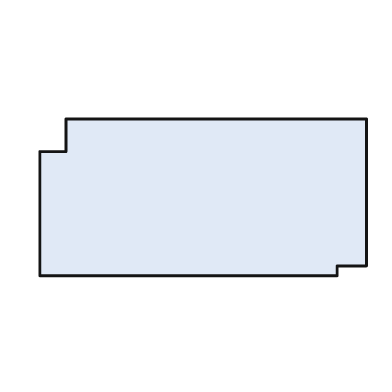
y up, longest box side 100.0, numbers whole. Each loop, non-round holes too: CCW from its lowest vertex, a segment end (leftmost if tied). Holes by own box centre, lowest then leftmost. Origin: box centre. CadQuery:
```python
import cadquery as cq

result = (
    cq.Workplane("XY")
    .moveTo(-50.0, -24.0)
    .lineTo(41.0, -24.0)
    .lineTo(41.0, -21.0)
    .lineTo(50.0, -21.0)
    .lineTo(50.0, 24.0)
    .lineTo(-42.0, 24.0)
    .lineTo(-42.0, 14.0)
    .lineTo(-50.0, 14.0)
    .close()
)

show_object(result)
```